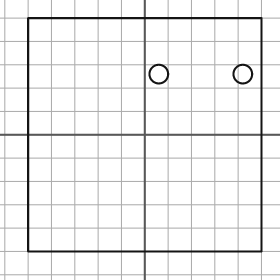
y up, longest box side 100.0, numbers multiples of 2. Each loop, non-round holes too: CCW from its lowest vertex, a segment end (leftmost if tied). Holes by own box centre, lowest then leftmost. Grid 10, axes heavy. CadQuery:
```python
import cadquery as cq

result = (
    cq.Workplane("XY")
    .moveTo(-50.0, -50.0)
    .lineTo(50.0, -50.0)
    .lineTo(50.0, 50.0)
    .lineTo(-50.0, 50.0)
    .close()
    .moveTo(6.0, 26.0)
    .circle(4.0)
    .moveTo(42.0, 26.0)
    .circle(4.0)
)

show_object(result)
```